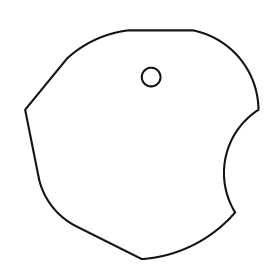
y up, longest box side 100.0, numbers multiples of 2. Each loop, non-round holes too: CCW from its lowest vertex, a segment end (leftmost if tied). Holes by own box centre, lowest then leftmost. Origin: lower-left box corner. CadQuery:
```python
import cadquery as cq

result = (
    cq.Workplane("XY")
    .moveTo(50.0, 0.0)
    .threePointArc((72.0, 6.0), (90.0, 20.0))
    .threePointArc((86.0, 44.0), (100.0, 64.0))
    .threePointArc((92.0, 86.0), (72.0, 98.0))
    .lineTo(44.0, 98.0)
    .threePointArc((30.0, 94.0), (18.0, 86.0))
    .lineTo(0.0, 64.0)
    .lineTo(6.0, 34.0)
    .threePointArc((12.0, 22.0), (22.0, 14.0))
    .close()
    .moveTo(54.0, 78.0)
    .circle(4.0)
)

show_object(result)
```